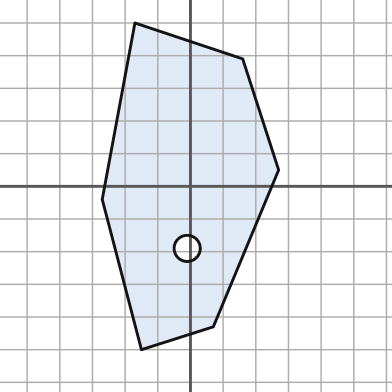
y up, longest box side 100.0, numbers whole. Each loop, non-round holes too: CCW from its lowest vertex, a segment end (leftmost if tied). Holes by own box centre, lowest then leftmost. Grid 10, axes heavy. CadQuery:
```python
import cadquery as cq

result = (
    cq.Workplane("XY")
    .moveTo(-15.0, -50.0)
    .lineTo(7.0, -43.0)
    .lineTo(27.0, 5.0)
    .lineTo(16.0, 39.0)
    .lineTo(-17.0, 50.0)
    .lineTo(-27.0, -4.0)
    .close()
    .moveTo(-1.0, -19.0)
    .circle(4.0)
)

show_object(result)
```